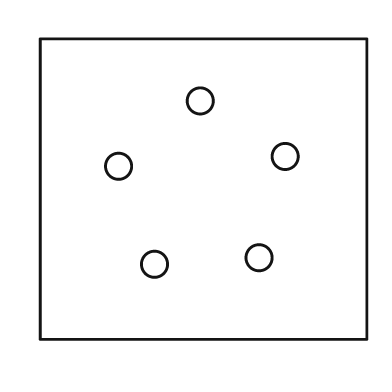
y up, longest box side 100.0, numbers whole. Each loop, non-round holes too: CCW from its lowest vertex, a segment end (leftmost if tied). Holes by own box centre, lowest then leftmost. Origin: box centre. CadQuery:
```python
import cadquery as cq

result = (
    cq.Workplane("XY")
    .moveTo(-50.0, -46.0)
    .lineTo(50.0, -46.0)
    .lineTo(50.0, 46.0)
    .lineTo(-50.0, 46.0)
    .close()
    .moveTo(-15.0, -23.0)
    .circle(4.0)
    .moveTo(17.0, -21.0)
    .circle(4.0)
    .moveTo(-26.0, 7.0)
    .circle(4.0)
    .moveTo(25.0, 10.0)
    .circle(4.0)
    .moveTo(-1.0, 27.0)
    .circle(4.0)
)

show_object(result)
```